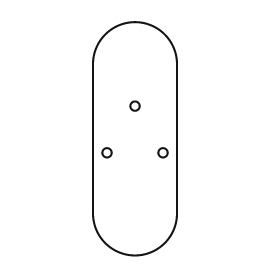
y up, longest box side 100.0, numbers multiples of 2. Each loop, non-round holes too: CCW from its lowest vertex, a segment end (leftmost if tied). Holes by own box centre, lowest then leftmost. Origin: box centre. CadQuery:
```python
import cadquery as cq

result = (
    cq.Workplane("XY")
    .moveTo(-18.0, -32.0)
    .threePointArc((0.0, -50.0), (18.0, -32.0))
    .lineTo(18.0, 32.0)
    .threePointArc((0.0, 50.0), (-18.0, 32.0))
    .close()
    .moveTo(-12.0, -6.0)
    .circle(2.0)
    .moveTo(12.0, -6.0)
    .circle(2.0)
    .moveTo(0.0, 14.0)
    .circle(2.0)
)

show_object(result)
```